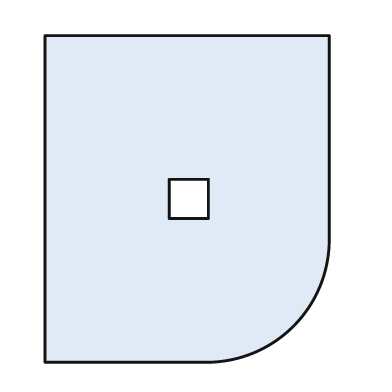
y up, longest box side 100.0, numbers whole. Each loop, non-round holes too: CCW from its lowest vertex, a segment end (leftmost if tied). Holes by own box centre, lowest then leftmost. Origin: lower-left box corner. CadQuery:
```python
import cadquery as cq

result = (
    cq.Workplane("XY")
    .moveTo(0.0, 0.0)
    .lineTo(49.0, 0.0)
    .threePointArc((76.0, 11.0), (87.0, 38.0))
    .lineTo(87.0, 100.0)
    .lineTo(0.0, 100.0)
    .close()
    .moveTo(38.0, 44.0)
    .lineTo(50.0, 44.0)
    .lineTo(50.0, 56.0)
    .lineTo(38.0, 56.0)
    .close()
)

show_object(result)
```